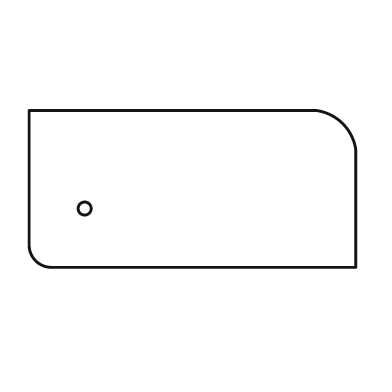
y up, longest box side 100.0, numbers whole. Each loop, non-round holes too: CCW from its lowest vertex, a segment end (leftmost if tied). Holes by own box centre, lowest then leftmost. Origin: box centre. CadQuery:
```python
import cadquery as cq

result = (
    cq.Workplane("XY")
    .moveTo(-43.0, -24.0)
    .lineTo(50.0, -24.0)
    .lineTo(50.0, 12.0)
    .threePointArc((46.0, 20.0), (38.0, 24.0))
    .lineTo(-50.0, 24.0)
    .lineTo(-50.0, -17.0)
    .threePointArc((-48.0, -22.0), (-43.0, -24.0))
    .close()
    .moveTo(-33.0, -6.0)
    .circle(2.0)
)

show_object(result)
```